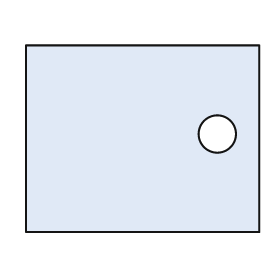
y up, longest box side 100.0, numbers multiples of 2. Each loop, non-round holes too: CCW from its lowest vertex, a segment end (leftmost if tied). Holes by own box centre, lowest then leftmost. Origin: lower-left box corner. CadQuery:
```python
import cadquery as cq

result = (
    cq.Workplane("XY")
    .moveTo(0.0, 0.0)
    .lineTo(100.0, 0.0)
    .lineTo(100.0, 80.0)
    .lineTo(0.0, 80.0)
    .close()
    .moveTo(82.0, 42.0)
    .circle(8.0)
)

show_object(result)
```